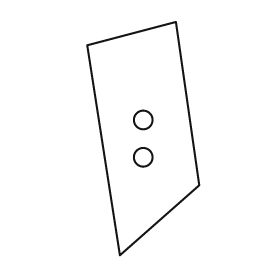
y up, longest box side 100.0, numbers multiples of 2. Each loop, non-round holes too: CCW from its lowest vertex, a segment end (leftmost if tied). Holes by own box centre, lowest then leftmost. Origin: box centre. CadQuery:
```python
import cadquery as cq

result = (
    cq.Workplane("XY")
    .moveTo(-10.0, -50.0)
    .lineTo(24.0, -20.0)
    .lineTo(14.0, 50.0)
    .lineTo(-24.0, 40.0)
    .close()
    .moveTo(0.0, -8.0)
    .circle(4.0)
    .moveTo(0.0, 8.0)
    .circle(4.0)
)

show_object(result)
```